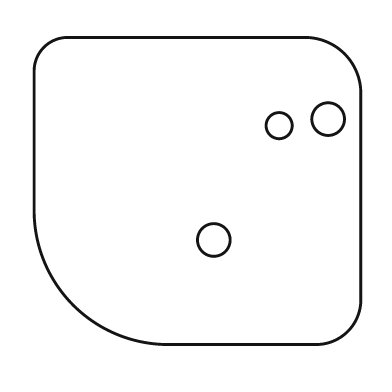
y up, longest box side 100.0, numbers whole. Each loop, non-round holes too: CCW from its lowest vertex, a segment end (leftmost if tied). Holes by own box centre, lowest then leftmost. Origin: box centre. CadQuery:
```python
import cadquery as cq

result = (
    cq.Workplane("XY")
    .moveTo(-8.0, -47.0)
    .lineTo(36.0, -47.0)
    .threePointArc((46.0, -43.0), (50.0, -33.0))
    .lineTo(50.0, 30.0)
    .threePointArc((45.0, 42.0), (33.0, 47.0))
    .lineTo(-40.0, 47.0)
    .threePointArc((-47.0, 44.0), (-50.0, 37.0))
    .lineTo(-50.0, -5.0)
    .threePointArc((-38.0, -35.0), (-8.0, -47.0))
    .close()
    .moveTo(5.0, -15.0)
    .circle(5.0)
    .moveTo(25.0, 20.0)
    .circle(4.0)
    .moveTo(40.0, 22.0)
    .circle(5.0)
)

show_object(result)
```